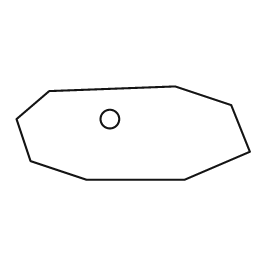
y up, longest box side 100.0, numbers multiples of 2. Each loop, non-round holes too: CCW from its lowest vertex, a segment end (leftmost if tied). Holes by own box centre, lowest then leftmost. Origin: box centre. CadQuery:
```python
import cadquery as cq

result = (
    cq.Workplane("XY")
    .moveTo(-20.0, -20.0)
    .lineTo(22.0, -20.0)
    .lineTo(50.0, -8.0)
    .lineTo(42.0, 12.0)
    .lineTo(18.0, 20.0)
    .lineTo(-36.0, 18.0)
    .lineTo(-50.0, 6.0)
    .lineTo(-44.0, -12.0)
    .close()
    .moveTo(-10.0, 6.0)
    .circle(4.0)
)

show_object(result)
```